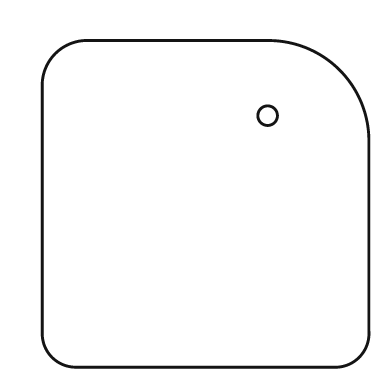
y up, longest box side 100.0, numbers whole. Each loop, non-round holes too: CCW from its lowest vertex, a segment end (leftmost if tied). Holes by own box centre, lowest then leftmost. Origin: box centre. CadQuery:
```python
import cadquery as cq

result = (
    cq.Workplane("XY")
    .moveTo(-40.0, -50.0)
    .lineTo(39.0, -50.0)
    .threePointArc((47.0, -47.0), (50.0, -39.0))
    .lineTo(50.0, 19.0)
    .threePointArc((41.0, 41.0), (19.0, 50.0))
    .lineTo(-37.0, 50.0)
    .threePointArc((-46.0, 46.0), (-50.0, 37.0))
    .lineTo(-50.0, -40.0)
    .threePointArc((-47.0, -47.0), (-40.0, -50.0))
    .close()
    .moveTo(19.0, 27.0)
    .circle(3.0)
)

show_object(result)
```